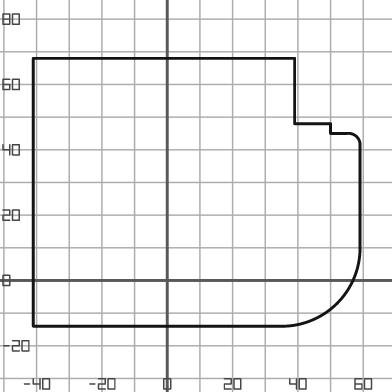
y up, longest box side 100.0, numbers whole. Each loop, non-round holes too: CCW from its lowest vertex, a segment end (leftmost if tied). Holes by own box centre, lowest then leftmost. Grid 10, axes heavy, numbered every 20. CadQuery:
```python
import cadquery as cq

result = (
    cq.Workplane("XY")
    .moveTo(-41.0, -14.0)
    .lineTo(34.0, -14.0)
    .threePointArc((52.0, -7.0), (59.0, 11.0))
    .lineTo(59.0, 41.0)
    .threePointArc((58.0, 44.0), (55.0, 45.0))
    .lineTo(50.0, 45.0)
    .lineTo(50.0, 48.0)
    .lineTo(39.0, 48.0)
    .lineTo(39.0, 68.0)
    .lineTo(-41.0, 68.0)
    .close()
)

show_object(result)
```